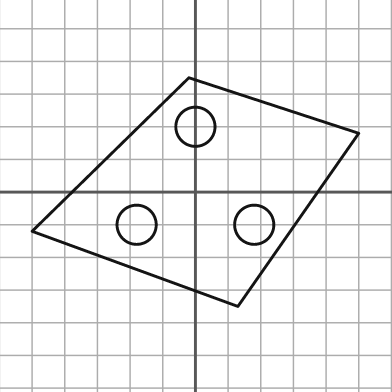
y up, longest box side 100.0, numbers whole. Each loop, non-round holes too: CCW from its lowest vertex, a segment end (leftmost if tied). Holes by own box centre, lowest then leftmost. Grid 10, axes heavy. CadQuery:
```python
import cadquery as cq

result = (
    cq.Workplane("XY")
    .moveTo(13.0, -35.0)
    .lineTo(50.0, 18.0)
    .lineTo(-2.0, 35.0)
    .lineTo(-50.0, -12.0)
    .close()
    .moveTo(-18.0, -10.0)
    .circle(6.0)
    .moveTo(18.0, -10.0)
    .circle(6.0)
    .moveTo(0.0, 20.0)
    .circle(6.0)
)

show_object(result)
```